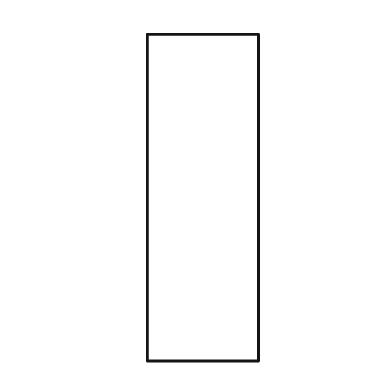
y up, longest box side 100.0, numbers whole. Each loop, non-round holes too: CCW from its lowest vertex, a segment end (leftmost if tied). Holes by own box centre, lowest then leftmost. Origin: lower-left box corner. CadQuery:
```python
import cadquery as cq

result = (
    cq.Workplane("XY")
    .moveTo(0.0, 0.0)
    .lineTo(34.0, 0.0)
    .lineTo(34.0, 100.0)
    .lineTo(0.0, 100.0)
    .close()
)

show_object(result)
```